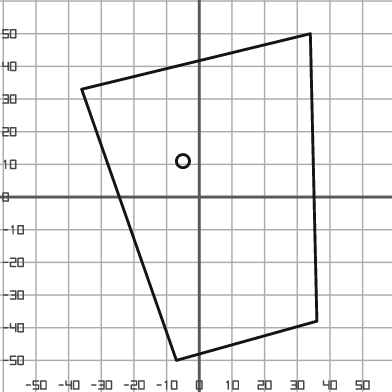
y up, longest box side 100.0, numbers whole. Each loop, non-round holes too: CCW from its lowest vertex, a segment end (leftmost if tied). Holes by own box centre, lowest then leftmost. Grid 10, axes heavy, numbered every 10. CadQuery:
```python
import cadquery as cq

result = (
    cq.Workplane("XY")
    .moveTo(-7.0, -50.0)
    .lineTo(36.0, -38.0)
    .lineTo(34.0, 50.0)
    .lineTo(-36.0, 33.0)
    .close()
    .moveTo(-5.0, 11.0)
    .circle(2.0)
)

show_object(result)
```